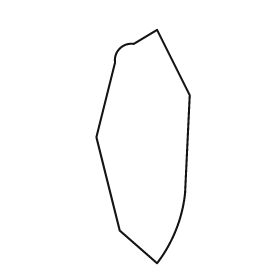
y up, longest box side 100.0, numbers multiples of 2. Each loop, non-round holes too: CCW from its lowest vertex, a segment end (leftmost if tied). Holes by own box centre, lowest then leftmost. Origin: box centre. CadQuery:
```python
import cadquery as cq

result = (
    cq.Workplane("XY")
    .moveTo(6.0, -50.0)
    .threePointArc((14.0, -36.0), (18.0, -20.0))
    .lineTo(20.0, 22.0)
    .lineTo(6.0, 50.0)
    .lineTo(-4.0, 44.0)
    .threePointArc((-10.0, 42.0), (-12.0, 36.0))
    .lineTo(-20.0, 4.0)
    .lineTo(-10.0, -36.0)
    .close()
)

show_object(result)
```